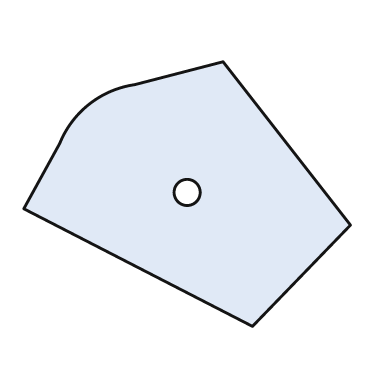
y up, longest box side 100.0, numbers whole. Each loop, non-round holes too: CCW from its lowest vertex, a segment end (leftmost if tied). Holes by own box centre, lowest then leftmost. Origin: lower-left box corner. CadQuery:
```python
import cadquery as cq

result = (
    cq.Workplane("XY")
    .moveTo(70.0, 0.0)
    .lineTo(100.0, 31.0)
    .lineTo(61.0, 81.0)
    .lineTo(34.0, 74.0)
    .threePointArc((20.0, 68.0), (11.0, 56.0))
    .lineTo(0.0, 36.0)
    .close()
    .moveTo(50.0, 41.0)
    .circle(4.0)
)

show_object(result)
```